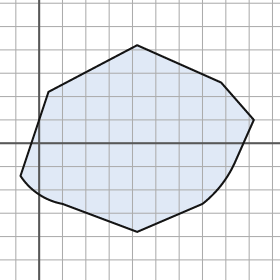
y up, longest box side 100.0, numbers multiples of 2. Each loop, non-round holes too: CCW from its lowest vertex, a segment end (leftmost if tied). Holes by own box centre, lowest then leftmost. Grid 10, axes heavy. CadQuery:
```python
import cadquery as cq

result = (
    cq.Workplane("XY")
    .moveTo(42.0, -38.0)
    .lineTo(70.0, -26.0)
    .threePointArc((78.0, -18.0), (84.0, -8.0))
    .lineTo(92.0, 10.0)
    .lineTo(78.0, 26.0)
    .lineTo(42.0, 42.0)
    .lineTo(4.0, 22.0)
    .lineTo(-8.0, -14.0)
    .threePointArc((0.0, -22.0), (10.0, -26.0))
    .close()
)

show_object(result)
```